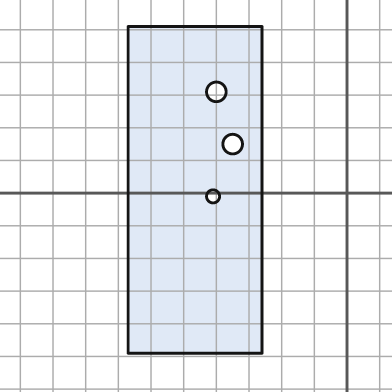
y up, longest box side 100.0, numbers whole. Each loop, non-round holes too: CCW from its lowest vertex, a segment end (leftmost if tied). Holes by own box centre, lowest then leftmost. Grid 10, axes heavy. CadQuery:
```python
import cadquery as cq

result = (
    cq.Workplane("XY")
    .moveTo(-67.0, -49.0)
    .lineTo(-26.0, -49.0)
    .lineTo(-26.0, 51.0)
    .lineTo(-67.0, 51.0)
    .close()
    .moveTo(-41.0, -1.0)
    .circle(2.0)
    .moveTo(-35.0, 15.0)
    .circle(3.0)
    .moveTo(-40.0, 31.0)
    .circle(3.0)
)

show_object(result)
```